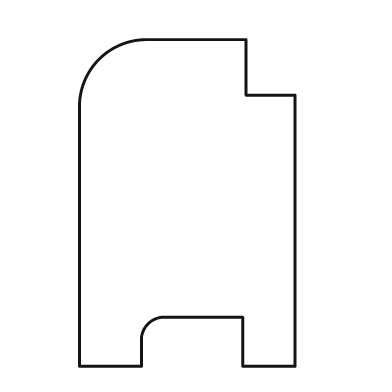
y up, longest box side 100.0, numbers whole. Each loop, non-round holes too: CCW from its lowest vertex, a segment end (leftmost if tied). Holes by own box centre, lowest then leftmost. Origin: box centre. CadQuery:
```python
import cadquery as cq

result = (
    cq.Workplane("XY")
    .moveTo(-33.0, -50.0)
    .lineTo(-14.0, -50.0)
    .lineTo(-14.0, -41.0)
    .threePointArc((-12.0, -37.0), (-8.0, -35.0))
    .lineTo(17.0, -35.0)
    .lineTo(17.0, -50.0)
    .lineTo(33.0, -50.0)
    .lineTo(33.0, 33.0)
    .lineTo(18.0, 33.0)
    .lineTo(18.0, 50.0)
    .lineTo(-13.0, 50.0)
    .threePointArc((-27.0, 44.0), (-33.0, 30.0))
    .close()
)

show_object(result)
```